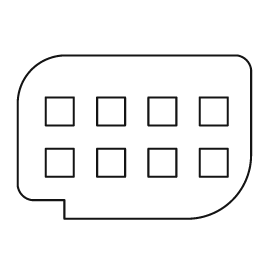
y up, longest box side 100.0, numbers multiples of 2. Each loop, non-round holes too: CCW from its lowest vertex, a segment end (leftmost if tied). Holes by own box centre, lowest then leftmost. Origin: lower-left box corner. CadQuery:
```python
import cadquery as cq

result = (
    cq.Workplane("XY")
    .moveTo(20.0, 0.0)
    .lineTo(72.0, 0.0)
    .threePointArc((92.0, 8.0), (100.0, 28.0))
    .lineTo(100.0, 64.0)
    .threePointArc((98.0, 68.0), (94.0, 70.0))
    .lineTo(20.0, 70.0)
    .threePointArc((6.0, 64.0), (0.0, 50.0))
    .lineTo(0.0, 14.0)
    .threePointArc((2.0, 10.0), (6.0, 8.0))
    .lineTo(20.0, 8.0)
    .close()
    .moveTo(12.0, 18.0)
    .lineTo(24.0, 18.0)
    .lineTo(24.0, 30.0)
    .lineTo(12.0, 30.0)
    .close()
    .moveTo(34.0, 18.0)
    .lineTo(46.0, 18.0)
    .lineTo(46.0, 30.0)
    .lineTo(34.0, 30.0)
    .close()
    .moveTo(56.0, 18.0)
    .lineTo(68.0, 18.0)
    .lineTo(68.0, 30.0)
    .lineTo(56.0, 30.0)
    .close()
    .moveTo(78.0, 18.0)
    .lineTo(90.0, 18.0)
    .lineTo(90.0, 30.0)
    .lineTo(78.0, 30.0)
    .close()
    .moveTo(12.0, 40.0)
    .lineTo(24.0, 40.0)
    .lineTo(24.0, 52.0)
    .lineTo(12.0, 52.0)
    .close()
    .moveTo(34.0, 40.0)
    .lineTo(46.0, 40.0)
    .lineTo(46.0, 52.0)
    .lineTo(34.0, 52.0)
    .close()
    .moveTo(56.0, 40.0)
    .lineTo(68.0, 40.0)
    .lineTo(68.0, 52.0)
    .lineTo(56.0, 52.0)
    .close()
    .moveTo(78.0, 40.0)
    .lineTo(90.0, 40.0)
    .lineTo(90.0, 52.0)
    .lineTo(78.0, 52.0)
    .close()
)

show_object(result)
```